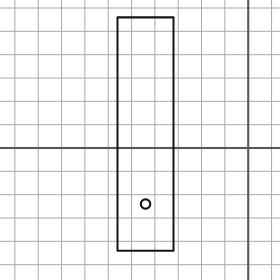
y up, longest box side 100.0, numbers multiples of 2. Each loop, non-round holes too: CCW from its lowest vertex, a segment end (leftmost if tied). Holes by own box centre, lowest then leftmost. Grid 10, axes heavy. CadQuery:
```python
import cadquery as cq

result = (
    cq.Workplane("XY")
    .moveTo(-56.0, -44.0)
    .lineTo(-32.0, -44.0)
    .lineTo(-32.0, 56.0)
    .lineTo(-56.0, 56.0)
    .close()
    .moveTo(-44.0, -24.0)
    .circle(2.0)
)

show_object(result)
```